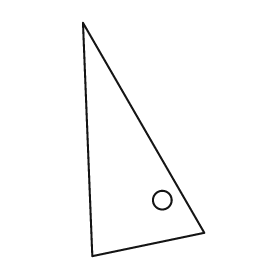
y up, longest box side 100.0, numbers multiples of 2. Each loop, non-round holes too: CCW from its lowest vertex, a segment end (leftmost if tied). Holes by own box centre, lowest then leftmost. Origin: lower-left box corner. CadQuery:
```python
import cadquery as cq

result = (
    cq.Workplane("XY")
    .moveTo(4.0, 0.0)
    .lineTo(52.0, 10.0)
    .lineTo(0.0, 100.0)
    .close()
    .moveTo(34.0, 24.0)
    .circle(4.0)
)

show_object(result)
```